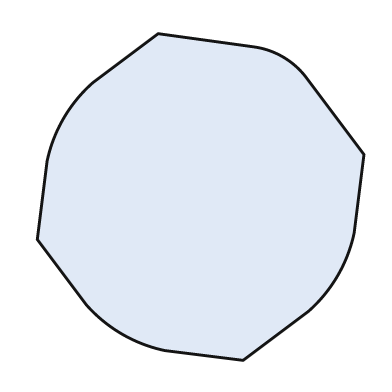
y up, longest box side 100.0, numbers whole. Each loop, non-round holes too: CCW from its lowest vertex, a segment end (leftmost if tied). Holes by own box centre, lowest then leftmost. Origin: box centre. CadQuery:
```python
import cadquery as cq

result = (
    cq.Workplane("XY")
    .moveTo(13.0, -50.0)
    .lineTo(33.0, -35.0)
    .threePointArc((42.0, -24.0), (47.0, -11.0))
    .lineTo(50.0, 13.0)
    .lineTo(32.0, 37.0)
    .threePointArc((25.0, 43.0), (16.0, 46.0))
    .lineTo(-13.0, 50.0)
    .lineTo(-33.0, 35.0)
    .threePointArc((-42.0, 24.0), (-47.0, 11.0))
    .lineTo(-50.0, -13.0)
    .lineTo(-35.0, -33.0)
    .threePointArc((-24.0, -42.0), (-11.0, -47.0))
    .close()
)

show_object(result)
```